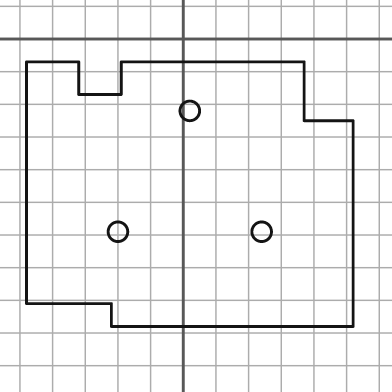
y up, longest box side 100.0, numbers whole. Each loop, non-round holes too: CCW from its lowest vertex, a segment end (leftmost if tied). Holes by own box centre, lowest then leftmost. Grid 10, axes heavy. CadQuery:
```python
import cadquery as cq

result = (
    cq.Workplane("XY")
    .moveTo(-22.0, -88.0)
    .lineTo(52.0, -88.0)
    .lineTo(52.0, -25.0)
    .lineTo(37.0, -25.0)
    .lineTo(37.0, -7.0)
    .lineTo(-19.0, -7.0)
    .lineTo(-19.0, -17.0)
    .lineTo(-32.0, -17.0)
    .lineTo(-32.0, -7.0)
    .lineTo(-48.0, -7.0)
    .lineTo(-48.0, -81.0)
    .lineTo(-22.0, -81.0)
    .close()
    .moveTo(-20.0, -59.0)
    .circle(3.0)
    .moveTo(24.0, -59.0)
    .circle(3.0)
    .moveTo(2.0, -22.0)
    .circle(3.0)
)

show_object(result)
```